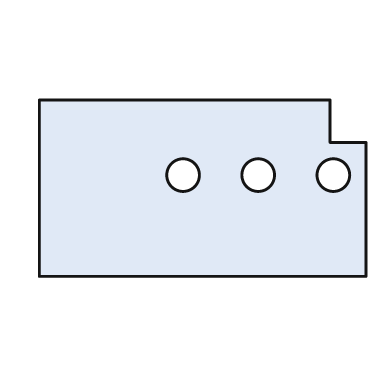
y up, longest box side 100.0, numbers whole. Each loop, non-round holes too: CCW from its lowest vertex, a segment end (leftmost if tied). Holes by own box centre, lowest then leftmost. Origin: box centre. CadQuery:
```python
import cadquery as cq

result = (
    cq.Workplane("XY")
    .moveTo(-50.0, -27.0)
    .lineTo(50.0, -27.0)
    .lineTo(50.0, 14.0)
    .lineTo(39.0, 14.0)
    .lineTo(39.0, 27.0)
    .lineTo(-50.0, 27.0)
    .close()
    .moveTo(-6.0, 4.0)
    .circle(5.0)
    .moveTo(17.0, 4.0)
    .circle(5.0)
    .moveTo(40.0, 4.0)
    .circle(5.0)
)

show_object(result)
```